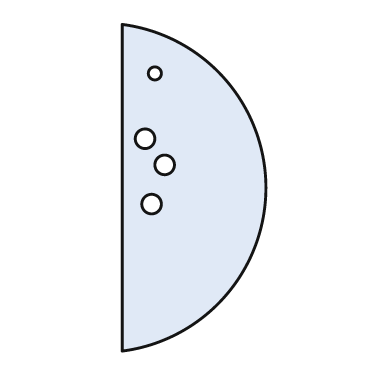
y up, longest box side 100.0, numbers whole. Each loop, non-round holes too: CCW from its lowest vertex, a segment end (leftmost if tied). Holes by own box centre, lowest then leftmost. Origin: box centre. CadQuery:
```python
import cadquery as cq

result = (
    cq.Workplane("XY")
    .moveTo(-22.0, -50.0)
    .threePointArc((22.0, 0.0), (-22.0, 50.0))
    .close()
    .moveTo(-13.0, -5.0)
    .circle(3.0)
    .moveTo(-9.0, 7.0)
    .circle(3.0)
    .moveTo(-15.0, 15.0)
    .circle(3.0)
    .moveTo(-12.0, 35.0)
    .circle(2.0)
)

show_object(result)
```